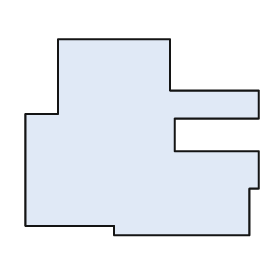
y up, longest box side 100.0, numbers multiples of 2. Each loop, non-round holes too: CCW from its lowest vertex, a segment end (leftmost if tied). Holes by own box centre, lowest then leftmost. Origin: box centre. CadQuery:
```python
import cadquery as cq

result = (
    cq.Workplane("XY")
    .moveTo(-12.0, -42.0)
    .lineTo(46.0, -42.0)
    .lineTo(46.0, -22.0)
    .lineTo(50.0, -22.0)
    .lineTo(50.0, -6.0)
    .lineTo(14.0, -6.0)
    .lineTo(14.0, 8.0)
    .lineTo(50.0, 8.0)
    .lineTo(50.0, 20.0)
    .lineTo(12.0, 20.0)
    .lineTo(12.0, 42.0)
    .lineTo(-36.0, 42.0)
    .lineTo(-36.0, 10.0)
    .lineTo(-50.0, 10.0)
    .lineTo(-50.0, -38.0)
    .lineTo(-12.0, -38.0)
    .close()
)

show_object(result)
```